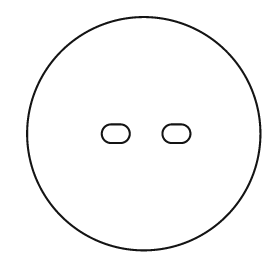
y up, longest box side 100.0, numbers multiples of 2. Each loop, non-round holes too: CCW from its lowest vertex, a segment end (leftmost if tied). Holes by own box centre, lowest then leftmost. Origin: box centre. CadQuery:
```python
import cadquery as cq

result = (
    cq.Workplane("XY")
    .moveTo(0.0, 0.0)
    .circle(50.0)
    .moveTo(-14.0, -4.0)
    .lineTo(-10.0, -4.0)
    .threePointArc((-6.0, 0.0), (-10.0, 4.0))
    .lineTo(-14.0, 4.0)
    .threePointArc((-18.0, 0.0), (-14.0, -4.0))
    .close()
    .moveTo(12.0, -4.0)
    .lineTo(16.0, -4.0)
    .threePointArc((20.0, 0.0), (16.0, 4.0))
    .lineTo(12.0, 4.0)
    .threePointArc((8.0, 0.0), (12.0, -4.0))
    .close()
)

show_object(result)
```